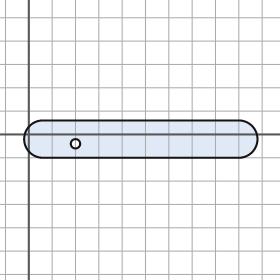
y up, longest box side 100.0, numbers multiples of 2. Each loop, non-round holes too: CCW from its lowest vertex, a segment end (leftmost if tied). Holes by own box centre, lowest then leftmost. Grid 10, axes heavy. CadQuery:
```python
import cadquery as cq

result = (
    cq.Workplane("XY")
    .moveTo(6.0, -10.0)
    .lineTo(90.0, -10.0)
    .threePointArc((98.0, -2.0), (90.0, 6.0))
    .lineTo(6.0, 6.0)
    .threePointArc((-2.0, -2.0), (6.0, -10.0))
    .close()
    .moveTo(20.0, -4.0)
    .circle(2.0)
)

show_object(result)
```